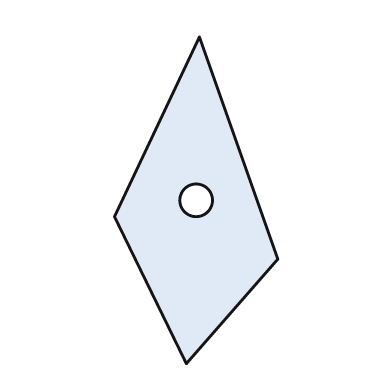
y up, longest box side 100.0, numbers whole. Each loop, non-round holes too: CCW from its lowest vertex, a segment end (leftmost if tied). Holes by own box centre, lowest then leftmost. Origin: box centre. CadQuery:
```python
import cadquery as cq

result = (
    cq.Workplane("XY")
    .moveTo(-3.0, -50.0)
    .lineTo(25.0, -18.0)
    .lineTo(1.0, 50.0)
    .lineTo(-25.0, -5.0)
    .close()
    .moveTo(0.0, 0.0)
    .circle(5.0)
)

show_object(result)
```